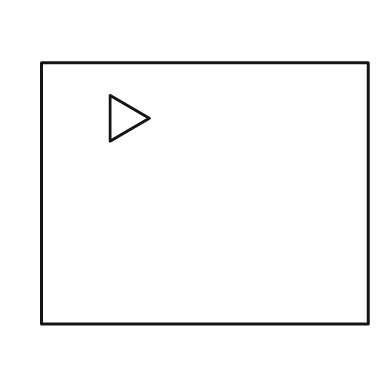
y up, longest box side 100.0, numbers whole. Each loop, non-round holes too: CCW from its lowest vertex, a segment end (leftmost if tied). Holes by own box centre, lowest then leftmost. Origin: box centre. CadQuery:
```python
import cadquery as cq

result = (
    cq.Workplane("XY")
    .moveTo(-50.0, -40.0)
    .lineTo(50.0, -40.0)
    .lineTo(50.0, 40.0)
    .lineTo(-50.0, 40.0)
    .close()
    .moveTo(-29.0, 16.0)
    .lineTo(-17.0, 23.0)
    .lineTo(-29.0, 30.0)
    .close()
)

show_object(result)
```